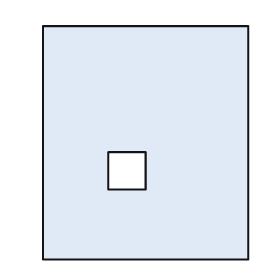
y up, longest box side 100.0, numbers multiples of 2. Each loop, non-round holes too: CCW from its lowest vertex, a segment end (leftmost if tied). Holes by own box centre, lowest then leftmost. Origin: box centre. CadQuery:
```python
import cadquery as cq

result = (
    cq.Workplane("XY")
    .moveTo(-44.0, -50.0)
    .lineTo(44.0, -50.0)
    .lineTo(44.0, 50.0)
    .lineTo(-44.0, 50.0)
    .close()
    .moveTo(-16.0, -20.0)
    .lineTo(0.0, -20.0)
    .lineTo(0.0, -4.0)
    .lineTo(-16.0, -4.0)
    .close()
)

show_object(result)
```